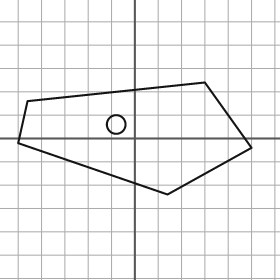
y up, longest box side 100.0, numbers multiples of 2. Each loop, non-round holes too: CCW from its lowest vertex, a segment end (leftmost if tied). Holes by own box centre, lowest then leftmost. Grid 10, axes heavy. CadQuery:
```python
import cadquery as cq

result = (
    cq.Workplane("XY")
    .moveTo(14.0, -24.0)
    .lineTo(50.0, -4.0)
    .lineTo(30.0, 24.0)
    .lineTo(-46.0, 16.0)
    .lineTo(-50.0, -2.0)
    .close()
    .moveTo(-8.0, 6.0)
    .circle(4.0)
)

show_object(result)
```